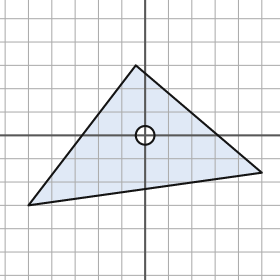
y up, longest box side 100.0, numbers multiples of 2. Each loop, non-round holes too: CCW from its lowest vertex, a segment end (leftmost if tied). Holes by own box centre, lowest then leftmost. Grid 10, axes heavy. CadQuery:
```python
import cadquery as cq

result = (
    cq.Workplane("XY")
    .moveTo(-50.0, -30.0)
    .lineTo(50.0, -16.0)
    .lineTo(-4.0, 30.0)
    .close()
    .moveTo(0.0, 0.0)
    .circle(4.0)
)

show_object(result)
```